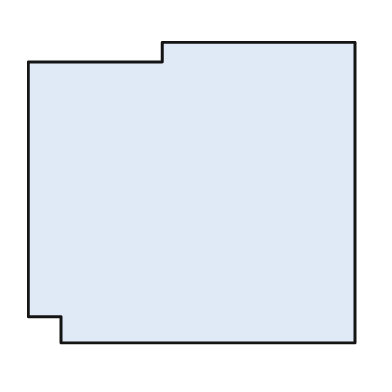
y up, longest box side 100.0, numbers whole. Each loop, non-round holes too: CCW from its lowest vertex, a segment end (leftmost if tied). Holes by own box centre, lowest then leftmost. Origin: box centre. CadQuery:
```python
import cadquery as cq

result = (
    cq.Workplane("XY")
    .moveTo(-40.0, -46.0)
    .lineTo(50.0, -46.0)
    .lineTo(50.0, 46.0)
    .lineTo(-9.0, 46.0)
    .lineTo(-9.0, 40.0)
    .lineTo(-50.0, 40.0)
    .lineTo(-50.0, -38.0)
    .lineTo(-40.0, -38.0)
    .close()
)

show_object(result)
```